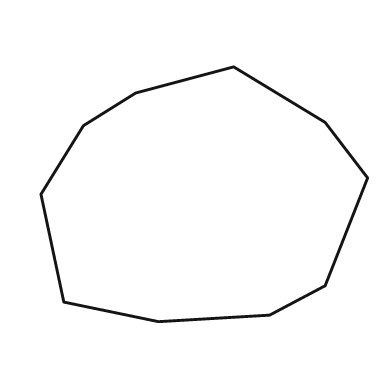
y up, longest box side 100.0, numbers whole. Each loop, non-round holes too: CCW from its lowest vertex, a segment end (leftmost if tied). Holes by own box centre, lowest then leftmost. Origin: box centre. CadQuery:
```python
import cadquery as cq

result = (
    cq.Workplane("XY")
    .moveTo(-14.0, -39.0)
    .lineTo(20.0, -37.0)
    .lineTo(37.0, -28.0)
    .lineTo(50.0, 5.0)
    .lineTo(37.0, 22.0)
    .lineTo(9.0, 39.0)
    .lineTo(-21.0, 31.0)
    .lineTo(-37.0, 21.0)
    .lineTo(-50.0, 0.0)
    .lineTo(-43.0, -33.0)
    .close()
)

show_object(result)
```